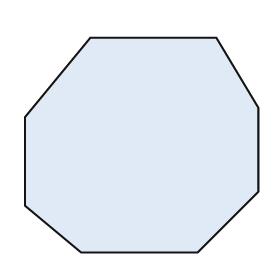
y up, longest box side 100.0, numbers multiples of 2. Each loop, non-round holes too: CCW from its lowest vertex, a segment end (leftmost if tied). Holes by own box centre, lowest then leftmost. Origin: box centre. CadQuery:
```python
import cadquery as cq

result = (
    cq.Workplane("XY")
    .moveTo(-26.0, -46.0)
    .lineTo(24.0, -46.0)
    .lineTo(50.0, -20.0)
    .lineTo(50.0, 16.0)
    .lineTo(32.0, 46.0)
    .lineTo(-22.0, 46.0)
    .lineTo(-50.0, 12.0)
    .lineTo(-50.0, -26.0)
    .close()
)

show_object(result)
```